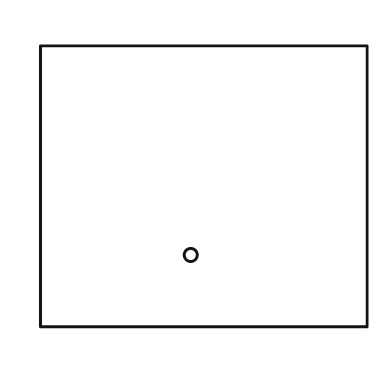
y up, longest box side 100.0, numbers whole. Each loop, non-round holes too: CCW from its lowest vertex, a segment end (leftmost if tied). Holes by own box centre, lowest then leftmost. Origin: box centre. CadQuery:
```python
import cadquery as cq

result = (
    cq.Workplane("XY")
    .moveTo(-50.0, -43.0)
    .lineTo(50.0, -43.0)
    .lineTo(50.0, 43.0)
    .lineTo(-50.0, 43.0)
    .close()
    .moveTo(-4.0, -21.0)
    .circle(2.0)
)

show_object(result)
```